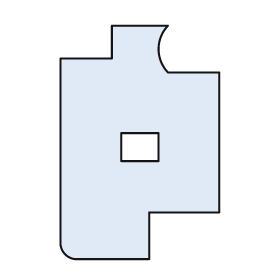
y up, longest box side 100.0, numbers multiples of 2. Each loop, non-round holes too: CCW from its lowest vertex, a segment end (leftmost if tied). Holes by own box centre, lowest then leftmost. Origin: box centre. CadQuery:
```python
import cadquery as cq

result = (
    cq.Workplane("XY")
    .moveTo(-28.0, -50.0)
    .lineTo(4.0, -50.0)
    .lineTo(4.0, -30.0)
    .lineTo(34.0, -30.0)
    .lineTo(34.0, 30.0)
    .lineTo(12.0, 30.0)
    .threePointArc((8.0, 40.0), (12.0, 50.0))
    .lineTo(-12.0, 50.0)
    .lineTo(-12.0, 36.0)
    .lineTo(-34.0, 36.0)
    .lineTo(-34.0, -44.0)
    .threePointArc((-32.0, -48.0), (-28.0, -50.0))
    .close()
    .moveTo(-8.0, -8.0)
    .lineTo(8.0, -8.0)
    .lineTo(8.0, 4.0)
    .lineTo(-8.0, 4.0)
    .close()
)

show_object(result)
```